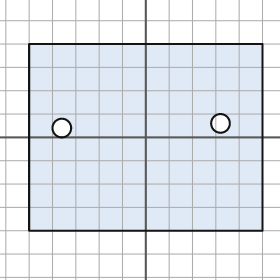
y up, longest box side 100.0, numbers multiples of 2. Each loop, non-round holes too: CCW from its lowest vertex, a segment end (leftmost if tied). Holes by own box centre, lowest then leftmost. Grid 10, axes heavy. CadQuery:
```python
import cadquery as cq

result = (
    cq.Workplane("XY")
    .moveTo(-50.0, -40.0)
    .lineTo(50.0, -40.0)
    .lineTo(50.0, 40.0)
    .lineTo(-50.0, 40.0)
    .close()
    .moveTo(-36.0, 4.0)
    .circle(4.0)
    .moveTo(32.0, 6.0)
    .circle(4.0)
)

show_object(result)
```